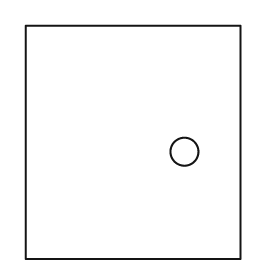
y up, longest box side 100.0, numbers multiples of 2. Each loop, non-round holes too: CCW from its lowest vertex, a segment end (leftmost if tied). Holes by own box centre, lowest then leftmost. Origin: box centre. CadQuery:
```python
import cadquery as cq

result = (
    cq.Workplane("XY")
    .moveTo(-46.0, -50.0)
    .lineTo(46.0, -50.0)
    .lineTo(46.0, 50.0)
    .lineTo(-46.0, 50.0)
    .close()
    .moveTo(22.0, -4.0)
    .circle(6.0)
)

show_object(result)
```